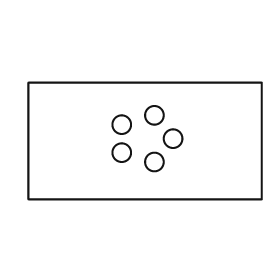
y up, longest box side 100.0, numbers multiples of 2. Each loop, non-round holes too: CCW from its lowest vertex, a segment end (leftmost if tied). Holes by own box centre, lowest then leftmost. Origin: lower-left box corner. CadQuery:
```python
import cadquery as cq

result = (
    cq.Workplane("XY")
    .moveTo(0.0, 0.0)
    .lineTo(100.0, 0.0)
    .lineTo(100.0, 50.0)
    .lineTo(0.0, 50.0)
    .close()
    .moveTo(54.0, 16.0)
    .circle(4.0)
    .moveTo(40.0, 20.0)
    .circle(4.0)
    .moveTo(62.0, 26.0)
    .circle(4.0)
    .moveTo(40.0, 32.0)
    .circle(4.0)
    .moveTo(54.0, 36.0)
    .circle(4.0)
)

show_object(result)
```